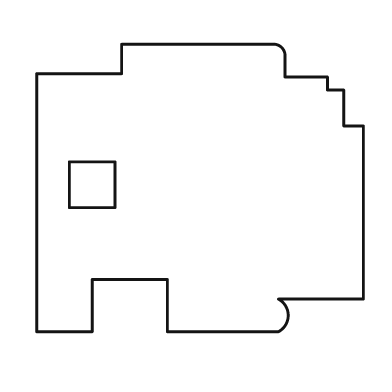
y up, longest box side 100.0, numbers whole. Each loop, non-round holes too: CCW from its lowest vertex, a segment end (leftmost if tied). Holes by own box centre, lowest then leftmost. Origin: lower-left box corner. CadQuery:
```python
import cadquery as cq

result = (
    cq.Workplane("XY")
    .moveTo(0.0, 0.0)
    .lineTo(17.0, 0.0)
    .lineTo(17.0, 16.0)
    .lineTo(40.0, 16.0)
    .lineTo(40.0, 0.0)
    .lineTo(74.0, 0.0)
    .threePointArc((77.0, 5.0), (74.0, 10.0))
    .lineTo(100.0, 10.0)
    .lineTo(100.0, 63.0)
    .lineTo(94.0, 63.0)
    .lineTo(94.0, 74.0)
    .lineTo(89.0, 74.0)
    .lineTo(89.0, 78.0)
    .lineTo(76.0, 78.0)
    .lineTo(76.0, 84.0)
    .threePointArc((75.0, 87.0), (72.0, 88.0))
    .lineTo(26.0, 88.0)
    .lineTo(26.0, 79.0)
    .lineTo(0.0, 79.0)
    .close()
    .moveTo(10.0, 38.0)
    .lineTo(24.0, 38.0)
    .lineTo(24.0, 52.0)
    .lineTo(10.0, 52.0)
    .close()
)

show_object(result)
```